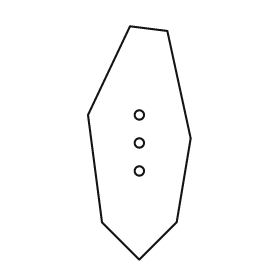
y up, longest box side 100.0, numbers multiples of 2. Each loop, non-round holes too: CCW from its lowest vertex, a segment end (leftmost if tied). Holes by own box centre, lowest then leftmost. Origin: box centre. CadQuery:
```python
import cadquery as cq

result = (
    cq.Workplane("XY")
    .moveTo(0.0, -50.0)
    .lineTo(16.0, -34.0)
    .lineTo(22.0, 2.0)
    .lineTo(12.0, 48.0)
    .lineTo(-4.0, 50.0)
    .lineTo(-22.0, 12.0)
    .lineTo(-16.0, -34.0)
    .close()
    .moveTo(0.0, -12.0)
    .circle(2.0)
    .moveTo(0.0, 0.0)
    .circle(2.0)
    .moveTo(0.0, 12.0)
    .circle(2.0)
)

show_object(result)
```